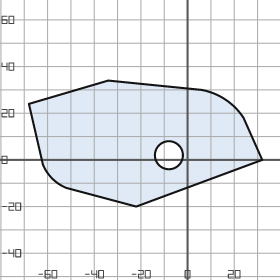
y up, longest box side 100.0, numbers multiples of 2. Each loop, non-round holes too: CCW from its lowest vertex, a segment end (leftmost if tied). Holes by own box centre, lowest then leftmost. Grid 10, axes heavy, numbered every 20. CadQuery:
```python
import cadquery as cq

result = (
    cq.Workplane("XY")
    .moveTo(-22.0, -20.0)
    .lineTo(32.0, 0.0)
    .lineTo(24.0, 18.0)
    .threePointArc((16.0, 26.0), (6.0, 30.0))
    .lineTo(-34.0, 34.0)
    .lineTo(-68.0, 24.0)
    .lineTo(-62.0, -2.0)
    .threePointArc((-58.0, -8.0), (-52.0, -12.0))
    .close()
    .moveTo(-8.0, 2.0)
    .circle(6.0)
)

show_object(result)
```